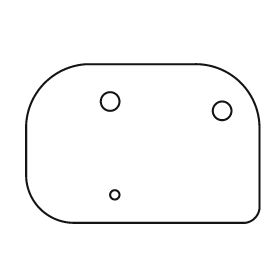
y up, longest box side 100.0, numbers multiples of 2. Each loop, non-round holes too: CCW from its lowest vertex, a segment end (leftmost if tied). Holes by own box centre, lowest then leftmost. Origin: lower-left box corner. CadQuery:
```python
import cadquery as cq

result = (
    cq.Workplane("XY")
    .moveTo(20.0, 0.0)
    .lineTo(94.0, 0.0)
    .threePointArc((98.0, 2.0), (100.0, 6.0))
    .lineTo(100.0, 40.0)
    .threePointArc((92.0, 60.0), (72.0, 68.0))
    .lineTo(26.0, 68.0)
    .threePointArc((8.0, 60.0), (0.0, 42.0))
    .lineTo(0.0, 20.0)
    .threePointArc((6.0, 6.0), (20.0, 0.0))
    .close()
    .moveTo(38.0, 12.0)
    .circle(2.0)
    .moveTo(84.0, 48.0)
    .circle(4.0)
    .moveTo(36.0, 52.0)
    .circle(4.0)
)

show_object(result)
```